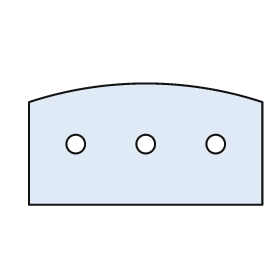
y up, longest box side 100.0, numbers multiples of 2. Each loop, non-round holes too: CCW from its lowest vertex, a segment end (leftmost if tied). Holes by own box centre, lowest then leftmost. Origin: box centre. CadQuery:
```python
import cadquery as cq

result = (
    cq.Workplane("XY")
    .moveTo(-50.0, -26.0)
    .lineTo(50.0, -26.0)
    .lineTo(50.0, 18.0)
    .threePointArc((0.0, 26.0), (-50.0, 18.0))
    .close()
    .moveTo(-30.0, 0.0)
    .circle(4.0)
    .moveTo(0.0, 0.0)
    .circle(4.0)
    .moveTo(30.0, 0.0)
    .circle(4.0)
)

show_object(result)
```